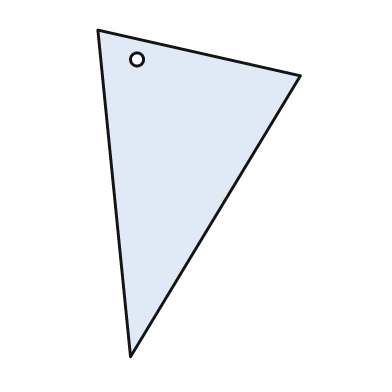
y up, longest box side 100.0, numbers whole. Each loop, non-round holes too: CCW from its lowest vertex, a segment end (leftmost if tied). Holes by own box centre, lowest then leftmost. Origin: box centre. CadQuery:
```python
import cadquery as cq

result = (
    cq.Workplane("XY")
    .moveTo(-21.0, -50.0)
    .lineTo(31.0, 36.0)
    .lineTo(-31.0, 50.0)
    .close()
    .moveTo(-19.0, 41.0)
    .circle(2.0)
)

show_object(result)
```